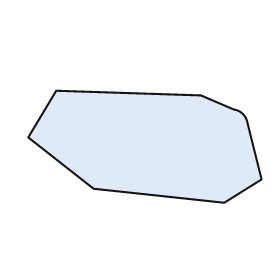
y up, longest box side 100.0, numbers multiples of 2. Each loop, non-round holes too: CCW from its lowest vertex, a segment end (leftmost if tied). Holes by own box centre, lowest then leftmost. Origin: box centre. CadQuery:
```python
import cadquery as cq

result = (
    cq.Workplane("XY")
    .moveTo(34.0, -24.0)
    .lineTo(50.0, -14.0)
    .lineTo(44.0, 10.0)
    .threePointArc((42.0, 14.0), (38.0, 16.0))
    .lineTo(24.0, 22.0)
    .lineTo(-38.0, 24.0)
    .lineTo(-50.0, 4.0)
    .lineTo(-22.0, -18.0)
    .close()
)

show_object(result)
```